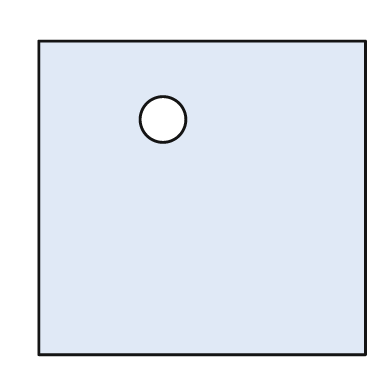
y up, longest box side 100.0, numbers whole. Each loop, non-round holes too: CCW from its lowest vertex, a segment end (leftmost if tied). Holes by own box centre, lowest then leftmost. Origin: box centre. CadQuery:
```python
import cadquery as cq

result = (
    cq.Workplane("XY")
    .moveTo(-50.0, -48.0)
    .lineTo(50.0, -48.0)
    .lineTo(50.0, 48.0)
    .lineTo(-50.0, 48.0)
    .close()
    .moveTo(-12.0, 24.0)
    .circle(7.0)
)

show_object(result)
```